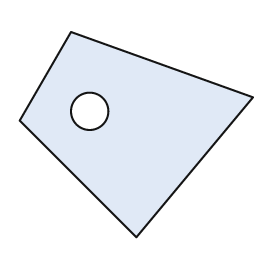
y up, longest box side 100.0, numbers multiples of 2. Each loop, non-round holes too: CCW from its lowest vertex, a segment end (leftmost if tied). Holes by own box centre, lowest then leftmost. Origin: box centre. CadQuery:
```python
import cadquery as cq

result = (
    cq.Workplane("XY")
    .moveTo(0.0, -44.0)
    .lineTo(50.0, 16.0)
    .lineTo(-28.0, 44.0)
    .lineTo(-50.0, 6.0)
    .close()
    .moveTo(-20.0, 10.0)
    .circle(8.0)
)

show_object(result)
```